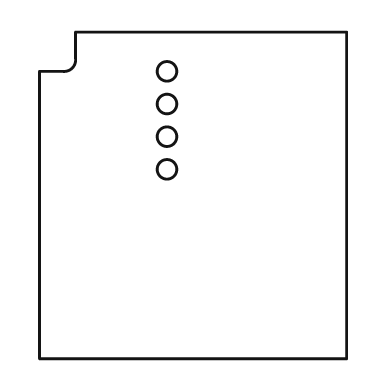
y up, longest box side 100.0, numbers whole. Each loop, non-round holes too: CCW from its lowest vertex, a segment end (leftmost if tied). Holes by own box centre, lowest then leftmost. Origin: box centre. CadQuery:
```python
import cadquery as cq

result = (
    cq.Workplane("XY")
    .moveTo(-47.0, -50.0)
    .lineTo(47.0, -50.0)
    .lineTo(47.0, 50.0)
    .lineTo(-36.0, 50.0)
    .lineTo(-36.0, 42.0)
    .threePointArc((-37.0, 39.0), (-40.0, 38.0))
    .lineTo(-47.0, 38.0)
    .close()
    .moveTo(-8.0, 8.0)
    .circle(3.0)
    .moveTo(-8.0, 18.0)
    .circle(3.0)
    .moveTo(-8.0, 28.0)
    .circle(3.0)
    .moveTo(-8.0, 38.0)
    .circle(3.0)
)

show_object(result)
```